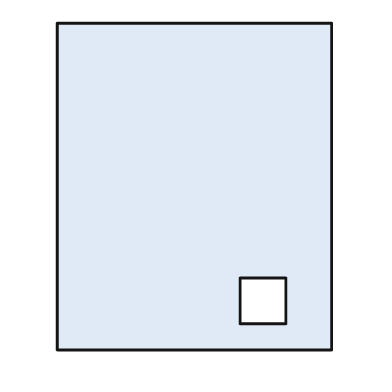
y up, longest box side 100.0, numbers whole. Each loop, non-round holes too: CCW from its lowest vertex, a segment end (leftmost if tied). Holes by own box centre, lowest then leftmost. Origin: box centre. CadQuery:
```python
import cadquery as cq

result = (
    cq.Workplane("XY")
    .moveTo(-42.0, -50.0)
    .lineTo(42.0, -50.0)
    .lineTo(42.0, 50.0)
    .lineTo(-42.0, 50.0)
    .close()
    .moveTo(14.0, -42.0)
    .lineTo(28.0, -42.0)
    .lineTo(28.0, -28.0)
    .lineTo(14.0, -28.0)
    .close()
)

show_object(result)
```